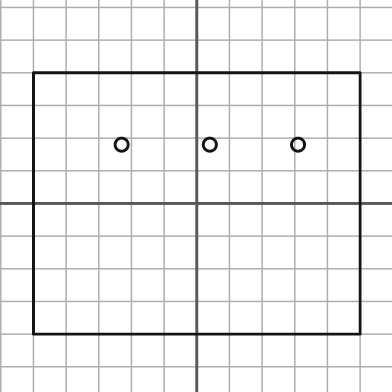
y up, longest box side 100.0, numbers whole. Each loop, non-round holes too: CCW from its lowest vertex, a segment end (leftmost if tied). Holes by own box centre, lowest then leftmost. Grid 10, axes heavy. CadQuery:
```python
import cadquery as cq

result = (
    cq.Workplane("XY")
    .moveTo(-50.0, -40.0)
    .lineTo(50.0, -40.0)
    .lineTo(50.0, 40.0)
    .lineTo(-50.0, 40.0)
    .close()
    .moveTo(-23.0, 18.0)
    .circle(2.0)
    .moveTo(4.0, 18.0)
    .circle(2.0)
    .moveTo(31.0, 18.0)
    .circle(2.0)
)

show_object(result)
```